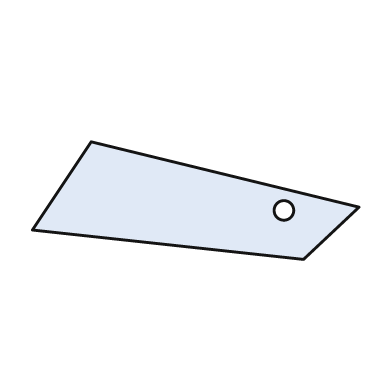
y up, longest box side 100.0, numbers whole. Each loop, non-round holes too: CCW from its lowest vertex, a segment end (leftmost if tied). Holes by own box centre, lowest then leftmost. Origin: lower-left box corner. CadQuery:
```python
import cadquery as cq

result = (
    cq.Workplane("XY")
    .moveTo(83.0, 0.0)
    .lineTo(100.0, 16.0)
    .lineTo(18.0, 36.0)
    .lineTo(0.0, 9.0)
    .close()
    .moveTo(77.0, 15.0)
    .circle(3.0)
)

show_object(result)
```